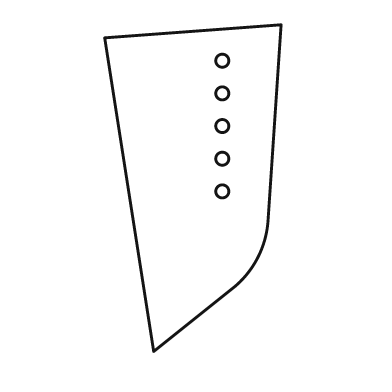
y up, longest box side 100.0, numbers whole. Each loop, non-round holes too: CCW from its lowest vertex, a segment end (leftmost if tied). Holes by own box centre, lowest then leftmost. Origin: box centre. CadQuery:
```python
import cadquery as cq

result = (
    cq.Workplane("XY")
    .moveTo(-12.0, -50.0)
    .lineTo(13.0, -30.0)
    .threePointArc((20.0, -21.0), (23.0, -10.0))
    .lineTo(27.0, 50.0)
    .lineTo(-27.0, 46.0)
    .close()
    .moveTo(9.0, -1.0)
    .circle(2.0)
    .moveTo(9.0, 9.0)
    .circle(2.0)
    .moveTo(9.0, 19.0)
    .circle(2.0)
    .moveTo(9.0, 29.0)
    .circle(2.0)
    .moveTo(9.0, 39.0)
    .circle(2.0)
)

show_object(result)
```